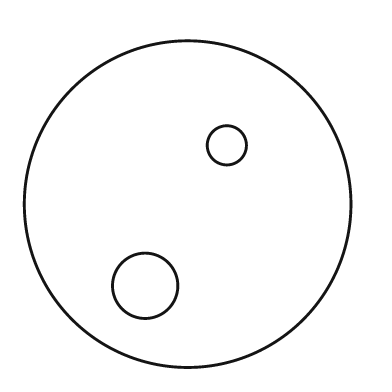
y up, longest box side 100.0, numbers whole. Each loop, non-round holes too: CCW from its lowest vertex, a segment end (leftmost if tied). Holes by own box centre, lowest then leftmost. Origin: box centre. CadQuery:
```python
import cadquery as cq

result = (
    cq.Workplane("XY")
    .moveTo(0.0, 0.0)
    .circle(50.0)
    .moveTo(-13.0, -25.0)
    .circle(10.0)
    .moveTo(12.0, 18.0)
    .circle(6.0)
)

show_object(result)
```